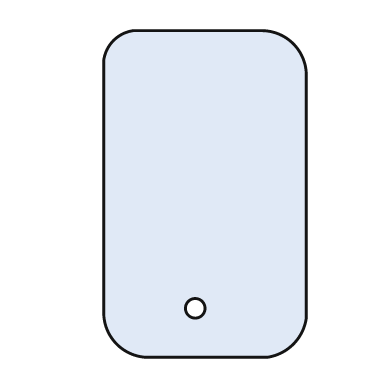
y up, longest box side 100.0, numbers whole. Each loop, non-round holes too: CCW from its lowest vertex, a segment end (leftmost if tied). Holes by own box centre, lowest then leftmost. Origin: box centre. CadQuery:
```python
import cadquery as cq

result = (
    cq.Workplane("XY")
    .moveTo(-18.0, -50.0)
    .lineTo(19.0, -50.0)
    .threePointArc((27.0, -46.0), (31.0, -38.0))
    .lineTo(31.0, 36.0)
    .threePointArc((27.0, 46.0), (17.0, 50.0))
    .lineTo(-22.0, 50.0)
    .threePointArc((-28.0, 47.0), (-31.0, 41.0))
    .lineTo(-31.0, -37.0)
    .threePointArc((-27.0, -46.0), (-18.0, -50.0))
    .close()
    .moveTo(-3.0, -35.0)
    .circle(3.0)
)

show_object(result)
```